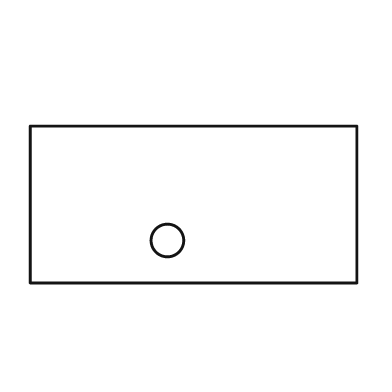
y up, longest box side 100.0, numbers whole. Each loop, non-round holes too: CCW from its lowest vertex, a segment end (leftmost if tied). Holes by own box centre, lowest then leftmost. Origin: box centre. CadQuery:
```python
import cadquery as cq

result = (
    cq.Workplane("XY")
    .moveTo(-50.0, -24.0)
    .lineTo(50.0, -24.0)
    .lineTo(50.0, 24.0)
    .lineTo(-50.0, 24.0)
    .close()
    .moveTo(-8.0, -11.0)
    .circle(5.0)
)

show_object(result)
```